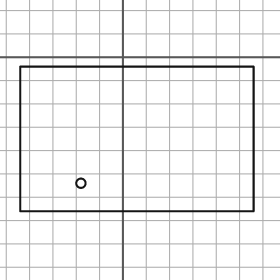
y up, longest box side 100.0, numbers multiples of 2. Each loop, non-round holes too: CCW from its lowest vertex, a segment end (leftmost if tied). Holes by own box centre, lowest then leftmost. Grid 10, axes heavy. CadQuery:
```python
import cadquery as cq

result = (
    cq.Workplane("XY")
    .moveTo(-44.0, -66.0)
    .lineTo(56.0, -66.0)
    .lineTo(56.0, -4.0)
    .lineTo(-44.0, -4.0)
    .close()
    .moveTo(-18.0, -54.0)
    .circle(2.0)
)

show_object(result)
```